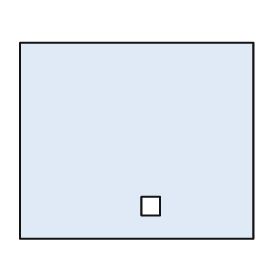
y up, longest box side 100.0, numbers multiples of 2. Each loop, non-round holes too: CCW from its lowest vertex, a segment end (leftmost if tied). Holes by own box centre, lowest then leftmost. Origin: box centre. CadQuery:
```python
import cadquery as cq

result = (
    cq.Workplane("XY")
    .moveTo(-50.0, -42.0)
    .lineTo(50.0, -42.0)
    .lineTo(50.0, 42.0)
    .lineTo(-50.0, 42.0)
    .close()
    .moveTo(2.0, -32.0)
    .lineTo(10.0, -32.0)
    .lineTo(10.0, -24.0)
    .lineTo(2.0, -24.0)
    .close()
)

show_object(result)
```